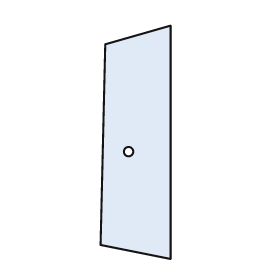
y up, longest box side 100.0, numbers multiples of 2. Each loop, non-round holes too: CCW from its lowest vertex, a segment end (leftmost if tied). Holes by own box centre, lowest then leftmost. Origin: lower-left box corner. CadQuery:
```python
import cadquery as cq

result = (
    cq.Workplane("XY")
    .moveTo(30.0, 0.0)
    .lineTo(30.0, 100.0)
    .lineTo(2.0, 92.0)
    .lineTo(0.0, 6.0)
    .close()
    .moveTo(12.0, 46.0)
    .circle(2.0)
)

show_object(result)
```